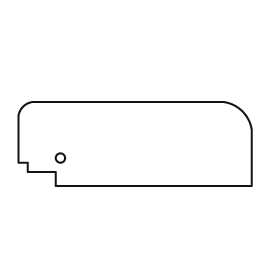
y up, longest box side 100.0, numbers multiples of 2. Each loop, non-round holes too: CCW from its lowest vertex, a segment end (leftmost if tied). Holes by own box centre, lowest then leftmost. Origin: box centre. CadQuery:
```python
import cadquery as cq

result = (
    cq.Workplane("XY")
    .moveTo(-34.0, -18.0)
    .lineTo(50.0, -18.0)
    .lineTo(50.0, 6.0)
    .threePointArc((46.0, 14.0), (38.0, 18.0))
    .lineTo(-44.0, 18.0)
    .threePointArc((-48.0, 16.0), (-50.0, 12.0))
    .lineTo(-50.0, -8.0)
    .lineTo(-46.0, -8.0)
    .lineTo(-46.0, -12.0)
    .lineTo(-34.0, -12.0)
    .close()
    .moveTo(-32.0, -6.0)
    .circle(2.0)
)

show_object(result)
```